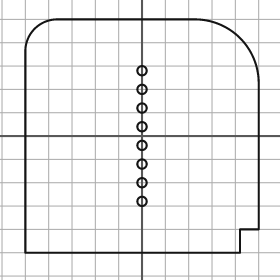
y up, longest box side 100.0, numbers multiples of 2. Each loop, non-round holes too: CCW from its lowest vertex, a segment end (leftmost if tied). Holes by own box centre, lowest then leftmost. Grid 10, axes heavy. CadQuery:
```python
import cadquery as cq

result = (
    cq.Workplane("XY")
    .moveTo(-50.0, -50.0)
    .lineTo(42.0, -50.0)
    .lineTo(42.0, -40.0)
    .lineTo(50.0, -40.0)
    .lineTo(50.0, 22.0)
    .threePointArc((42.0, 42.0), (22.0, 50.0))
    .lineTo(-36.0, 50.0)
    .threePointArc((-46.0, 46.0), (-50.0, 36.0))
    .close()
    .moveTo(0.0, -28.0)
    .circle(2.0)
    .moveTo(0.0, -20.0)
    .circle(2.0)
    .moveTo(0.0, -12.0)
    .circle(2.0)
    .moveTo(0.0, -4.0)
    .circle(2.0)
    .moveTo(0.0, 4.0)
    .circle(2.0)
    .moveTo(0.0, 12.0)
    .circle(2.0)
    .moveTo(0.0, 20.0)
    .circle(2.0)
    .moveTo(0.0, 28.0)
    .circle(2.0)
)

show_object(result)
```